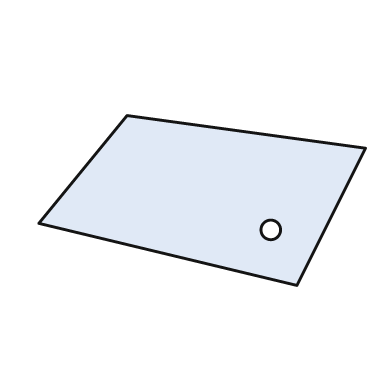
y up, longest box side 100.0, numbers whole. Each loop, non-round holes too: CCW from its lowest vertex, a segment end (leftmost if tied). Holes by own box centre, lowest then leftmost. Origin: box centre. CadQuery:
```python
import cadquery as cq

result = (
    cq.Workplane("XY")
    .moveTo(29.0, -26.0)
    .lineTo(50.0, 16.0)
    .lineTo(-23.0, 26.0)
    .lineTo(-50.0, -7.0)
    .close()
    .moveTo(21.0, -9.0)
    .circle(3.0)
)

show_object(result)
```